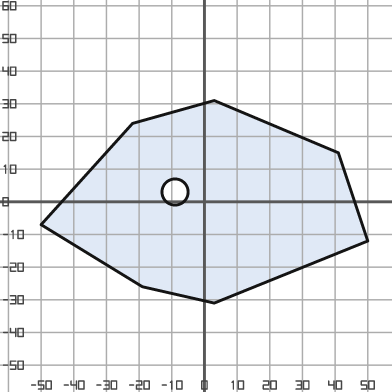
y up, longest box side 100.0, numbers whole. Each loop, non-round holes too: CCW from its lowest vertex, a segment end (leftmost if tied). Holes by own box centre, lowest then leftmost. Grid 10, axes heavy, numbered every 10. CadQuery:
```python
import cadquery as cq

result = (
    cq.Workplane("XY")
    .moveTo(3.0, -31.0)
    .lineTo(50.0, -12.0)
    .lineTo(41.0, 15.0)
    .lineTo(3.0, 31.0)
    .lineTo(-22.0, 24.0)
    .lineTo(-50.0, -7.0)
    .lineTo(-19.0, -26.0)
    .close()
    .moveTo(-9.0, 3.0)
    .circle(4.0)
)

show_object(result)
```